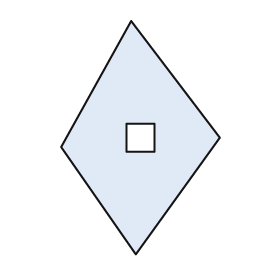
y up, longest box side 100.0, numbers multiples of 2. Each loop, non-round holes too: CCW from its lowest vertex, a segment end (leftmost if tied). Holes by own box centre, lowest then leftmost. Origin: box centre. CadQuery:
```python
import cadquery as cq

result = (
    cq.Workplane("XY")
    .moveTo(-2.0, -50.0)
    .lineTo(34.0, 0.0)
    .lineTo(-4.0, 50.0)
    .lineTo(-34.0, -4.0)
    .close()
    .moveTo(-6.0, -6.0)
    .lineTo(6.0, -6.0)
    .lineTo(6.0, 6.0)
    .lineTo(-6.0, 6.0)
    .close()
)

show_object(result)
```